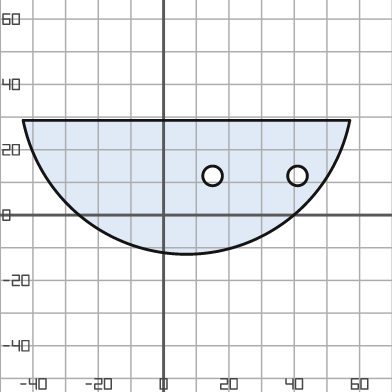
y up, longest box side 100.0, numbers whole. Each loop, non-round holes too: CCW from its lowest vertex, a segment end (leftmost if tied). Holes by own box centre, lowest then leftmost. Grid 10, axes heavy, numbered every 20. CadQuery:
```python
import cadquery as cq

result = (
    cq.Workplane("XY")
    .moveTo(-43.0, 29.0)
    .threePointArc((7.0, -12.0), (57.0, 29.0))
    .close()
    .moveTo(15.0, 12.0)
    .circle(3.0)
    .moveTo(41.0, 12.0)
    .circle(3.0)
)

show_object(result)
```